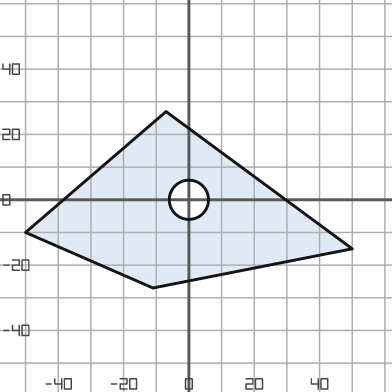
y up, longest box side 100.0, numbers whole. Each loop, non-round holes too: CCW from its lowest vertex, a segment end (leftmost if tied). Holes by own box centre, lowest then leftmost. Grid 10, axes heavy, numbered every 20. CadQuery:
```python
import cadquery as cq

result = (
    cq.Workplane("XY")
    .moveTo(-11.0, -27.0)
    .lineTo(50.0, -15.0)
    .lineTo(-7.0, 27.0)
    .lineTo(-50.0, -10.0)
    .close()
    .moveTo(0.0, 0.0)
    .circle(6.0)
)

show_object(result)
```